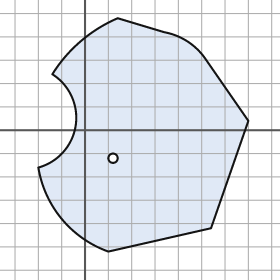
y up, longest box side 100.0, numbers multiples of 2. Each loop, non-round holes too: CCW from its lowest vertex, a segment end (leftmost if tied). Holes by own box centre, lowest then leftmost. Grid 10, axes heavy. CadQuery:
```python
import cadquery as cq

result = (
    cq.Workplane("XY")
    .moveTo(10.0, -52.0)
    .lineTo(54.0, -42.0)
    .lineTo(70.0, 4.0)
    .lineTo(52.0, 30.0)
    .threePointArc((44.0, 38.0), (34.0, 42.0))
    .lineTo(14.0, 48.0)
    .threePointArc((-2.0, 38.0), (-14.0, 24.0))
    .threePointArc((-4.0, 2.0), (-20.0, -16.0))
    .threePointArc((-10.0, -38.0), (10.0, -52.0))
    .close()
    .moveTo(12.0, -12.0)
    .circle(2.0)
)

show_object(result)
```